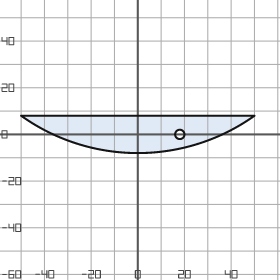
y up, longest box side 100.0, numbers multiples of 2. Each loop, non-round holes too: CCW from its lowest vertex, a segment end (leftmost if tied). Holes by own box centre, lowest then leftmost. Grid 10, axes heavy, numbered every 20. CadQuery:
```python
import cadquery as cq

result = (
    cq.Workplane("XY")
    .moveTo(-50.0, 8.0)
    .threePointArc((0.0, -8.0), (50.0, 8.0))
    .close()
    .moveTo(18.0, 0.0)
    .circle(2.0)
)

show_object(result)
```